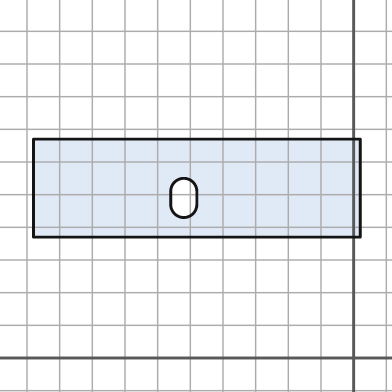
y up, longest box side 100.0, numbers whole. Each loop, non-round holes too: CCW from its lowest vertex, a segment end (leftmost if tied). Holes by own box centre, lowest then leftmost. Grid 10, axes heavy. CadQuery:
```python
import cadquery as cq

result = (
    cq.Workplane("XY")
    .moveTo(-98.0, 37.0)
    .lineTo(2.0, 37.0)
    .lineTo(2.0, 67.0)
    .lineTo(-98.0, 67.0)
    .close()
    .moveTo(-56.0, 47.0)
    .threePointArc((-52.0, 43.0), (-48.0, 47.0))
    .lineTo(-48.0, 51.0)
    .threePointArc((-52.0, 55.0), (-56.0, 51.0))
    .close()
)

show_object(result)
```